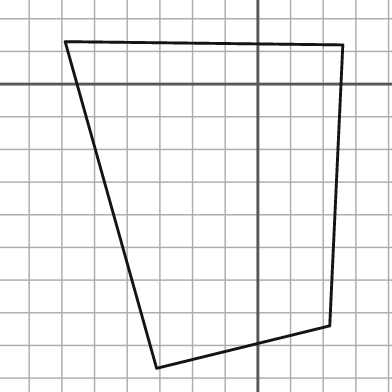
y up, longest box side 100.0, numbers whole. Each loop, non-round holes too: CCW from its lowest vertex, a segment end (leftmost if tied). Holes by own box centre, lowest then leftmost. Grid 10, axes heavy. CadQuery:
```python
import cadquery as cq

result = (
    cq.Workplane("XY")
    .moveTo(-31.0, -87.0)
    .lineTo(22.0, -74.0)
    .lineTo(26.0, 12.0)
    .lineTo(-59.0, 13.0)
    .close()
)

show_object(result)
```